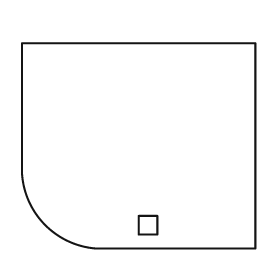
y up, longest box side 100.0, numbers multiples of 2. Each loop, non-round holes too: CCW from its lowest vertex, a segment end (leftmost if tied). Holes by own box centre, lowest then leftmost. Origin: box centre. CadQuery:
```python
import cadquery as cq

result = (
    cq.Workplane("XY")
    .moveTo(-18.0, -44.0)
    .lineTo(50.0, -44.0)
    .lineTo(50.0, 44.0)
    .lineTo(-50.0, 44.0)
    .lineTo(-50.0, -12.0)
    .threePointArc((-40.0, -34.0), (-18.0, -44.0))
    .close()
    .moveTo(0.0, -38.0)
    .lineTo(8.0, -38.0)
    .lineTo(8.0, -30.0)
    .lineTo(0.0, -30.0)
    .close()
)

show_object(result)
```